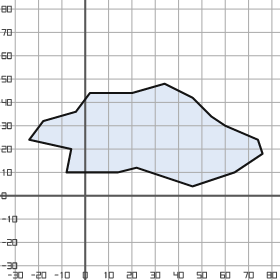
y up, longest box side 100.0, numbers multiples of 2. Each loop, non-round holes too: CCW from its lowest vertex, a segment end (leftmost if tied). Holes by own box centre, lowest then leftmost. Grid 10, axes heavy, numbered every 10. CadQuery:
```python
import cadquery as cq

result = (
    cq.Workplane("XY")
    .moveTo(46.0, 4.0)
    .lineTo(64.0, 10.0)
    .lineTo(76.0, 18.0)
    .lineTo(74.0, 24.0)
    .lineTo(60.0, 30.0)
    .lineTo(54.0, 34.0)
    .lineTo(46.0, 42.0)
    .lineTo(34.0, 48.0)
    .lineTo(20.0, 44.0)
    .lineTo(2.0, 44.0)
    .lineTo(-4.0, 36.0)
    .lineTo(-18.0, 32.0)
    .lineTo(-24.0, 24.0)
    .lineTo(-6.0, 20.0)
    .lineTo(-8.0, 10.0)
    .lineTo(14.0, 10.0)
    .lineTo(22.0, 12.0)
    .close()
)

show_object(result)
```